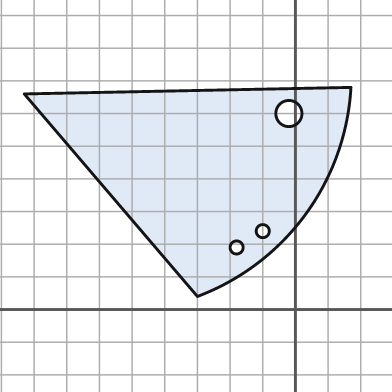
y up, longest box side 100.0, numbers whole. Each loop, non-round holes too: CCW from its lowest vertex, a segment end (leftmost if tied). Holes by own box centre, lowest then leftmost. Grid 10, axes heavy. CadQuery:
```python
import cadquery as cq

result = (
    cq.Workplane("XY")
    .moveTo(-30.0, 4.0)
    .threePointArc((3.0, 29.0), (17.0, 68.0))
    .lineTo(-83.0, 66.0)
    .close()
    .moveTo(-18.0, 19.0)
    .circle(2.0)
    .moveTo(-10.0, 24.0)
    .circle(2.0)
    .moveTo(-2.0, 60.0)
    .circle(4.0)
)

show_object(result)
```